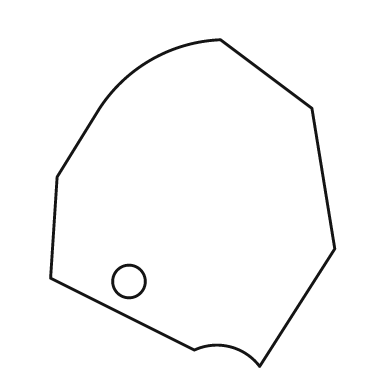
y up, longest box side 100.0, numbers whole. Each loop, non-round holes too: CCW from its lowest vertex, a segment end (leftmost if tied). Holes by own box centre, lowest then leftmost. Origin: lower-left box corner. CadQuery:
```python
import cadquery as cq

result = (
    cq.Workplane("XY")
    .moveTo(64.0, 0.0)
    .lineTo(87.0, 36.0)
    .lineTo(80.0, 79.0)
    .lineTo(52.0, 100.0)
    .threePointArc((31.0, 94.0), (15.0, 79.0))
    .lineTo(2.0, 58.0)
    .lineTo(0.0, 27.0)
    .lineTo(44.0, 5.0)
    .threePointArc((55.0, 6.0), (64.0, 0.0))
    .close()
    .moveTo(24.0, 26.0)
    .circle(5.0)
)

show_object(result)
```